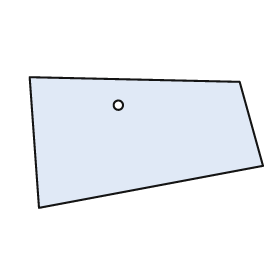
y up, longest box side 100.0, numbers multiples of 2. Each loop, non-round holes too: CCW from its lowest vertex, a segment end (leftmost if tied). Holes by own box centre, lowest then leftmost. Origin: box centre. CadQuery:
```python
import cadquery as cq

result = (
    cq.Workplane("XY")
    .moveTo(-46.0, -28.0)
    .lineTo(50.0, -10.0)
    .lineTo(40.0, 26.0)
    .lineTo(-50.0, 28.0)
    .close()
    .moveTo(-12.0, 16.0)
    .circle(2.0)
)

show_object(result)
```